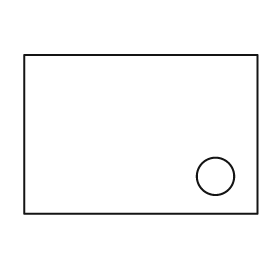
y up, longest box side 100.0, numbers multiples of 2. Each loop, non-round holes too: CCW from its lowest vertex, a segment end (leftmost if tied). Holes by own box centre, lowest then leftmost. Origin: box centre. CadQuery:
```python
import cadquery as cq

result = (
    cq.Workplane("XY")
    .moveTo(-50.0, -34.0)
    .lineTo(50.0, -34.0)
    .lineTo(50.0, 34.0)
    .lineTo(-50.0, 34.0)
    .close()
    .moveTo(32.0, -18.0)
    .circle(8.0)
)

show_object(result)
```